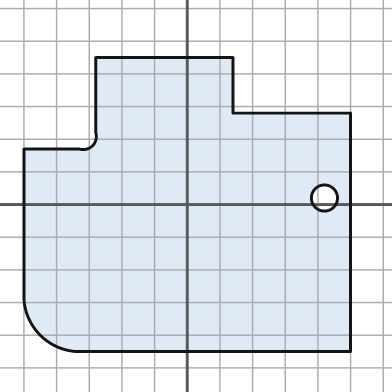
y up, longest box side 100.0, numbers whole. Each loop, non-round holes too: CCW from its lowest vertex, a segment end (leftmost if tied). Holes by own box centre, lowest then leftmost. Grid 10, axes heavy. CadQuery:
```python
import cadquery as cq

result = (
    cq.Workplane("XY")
    .moveTo(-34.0, -45.0)
    .lineTo(50.0, -45.0)
    .lineTo(50.0, 28.0)
    .lineTo(14.0, 28.0)
    .lineTo(14.0, 45.0)
    .lineTo(-28.0, 45.0)
    .lineTo(-28.0, 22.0)
    .threePointArc((-29.0, 18.0), (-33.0, 17.0))
    .lineTo(-50.0, 17.0)
    .lineTo(-50.0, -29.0)
    .threePointArc((-45.0, -40.0), (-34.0, -45.0))
    .close()
    .moveTo(42.0, 2.0)
    .circle(4.0)
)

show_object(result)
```